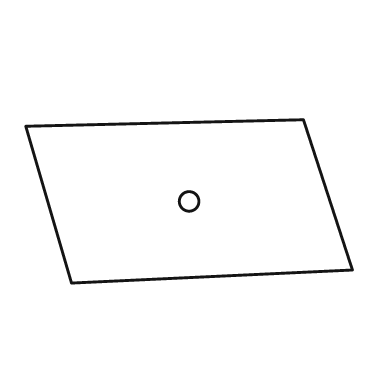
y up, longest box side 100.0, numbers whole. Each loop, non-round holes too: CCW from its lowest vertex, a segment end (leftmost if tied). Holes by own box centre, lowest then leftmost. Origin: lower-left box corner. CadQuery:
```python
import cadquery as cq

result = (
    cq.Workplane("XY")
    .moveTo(14.0, 0.0)
    .lineTo(100.0, 4.0)
    .lineTo(85.0, 50.0)
    .lineTo(0.0, 48.0)
    .close()
    .moveTo(50.0, 25.0)
    .circle(3.0)
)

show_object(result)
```